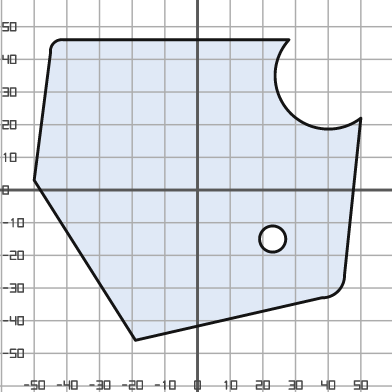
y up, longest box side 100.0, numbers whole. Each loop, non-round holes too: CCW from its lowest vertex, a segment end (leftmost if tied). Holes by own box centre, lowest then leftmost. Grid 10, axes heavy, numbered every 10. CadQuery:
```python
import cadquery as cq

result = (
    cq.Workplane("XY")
    .moveTo(-19.0, -46.0)
    .lineTo(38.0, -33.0)
    .threePointArc((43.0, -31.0), (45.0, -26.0))
    .lineTo(50.0, 22.0)
    .threePointArc((28.0, 24.0), (28.0, 46.0))
    .lineTo(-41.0, 46.0)
    .threePointArc((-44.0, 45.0), (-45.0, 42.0))
    .lineTo(-50.0, 3.0)
    .close()
    .moveTo(23.0, -15.0)
    .circle(4.0)
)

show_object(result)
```